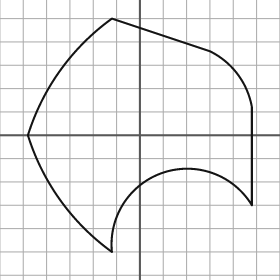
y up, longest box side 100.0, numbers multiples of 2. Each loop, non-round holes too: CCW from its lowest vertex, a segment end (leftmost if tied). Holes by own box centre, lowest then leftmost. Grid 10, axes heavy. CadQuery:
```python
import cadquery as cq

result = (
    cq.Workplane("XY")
    .moveTo(-12.0, -50.0)
    .threePointArc((10.0, -16.0), (48.0, -30.0))
    .lineTo(48.0, 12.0)
    .threePointArc((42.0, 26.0), (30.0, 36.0))
    .lineTo(-12.0, 50.0)
    .threePointArc((-34.0, 28.0), (-48.0, 0.0))
    .threePointArc((-34.0, -28.0), (-12.0, -50.0))
    .close()
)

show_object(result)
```